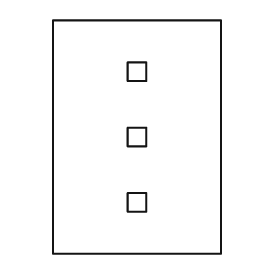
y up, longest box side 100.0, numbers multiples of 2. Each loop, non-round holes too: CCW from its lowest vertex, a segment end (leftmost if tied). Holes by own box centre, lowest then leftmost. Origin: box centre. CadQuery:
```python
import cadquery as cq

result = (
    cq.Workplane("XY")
    .moveTo(-36.0, -50.0)
    .lineTo(36.0, -50.0)
    .lineTo(36.0, 50.0)
    .lineTo(-36.0, 50.0)
    .close()
    .moveTo(-4.0, -32.0)
    .lineTo(4.0, -32.0)
    .lineTo(4.0, -24.0)
    .lineTo(-4.0, -24.0)
    .close()
    .moveTo(-4.0, -4.0)
    .lineTo(4.0, -4.0)
    .lineTo(4.0, 4.0)
    .lineTo(-4.0, 4.0)
    .close()
    .moveTo(-4.0, 24.0)
    .lineTo(4.0, 24.0)
    .lineTo(4.0, 32.0)
    .lineTo(-4.0, 32.0)
    .close()
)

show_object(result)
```